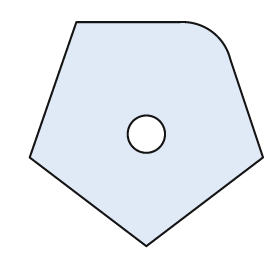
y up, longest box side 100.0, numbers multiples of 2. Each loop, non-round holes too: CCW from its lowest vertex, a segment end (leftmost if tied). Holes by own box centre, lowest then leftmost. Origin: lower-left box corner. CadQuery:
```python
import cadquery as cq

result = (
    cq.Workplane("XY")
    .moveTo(50.0, 0.0)
    .lineTo(100.0, 38.0)
    .lineTo(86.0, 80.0)
    .threePointArc((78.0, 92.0), (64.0, 96.0))
    .lineTo(20.0, 96.0)
    .lineTo(0.0, 38.0)
    .close()
    .moveTo(50.0, 48.0)
    .circle(8.0)
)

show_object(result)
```